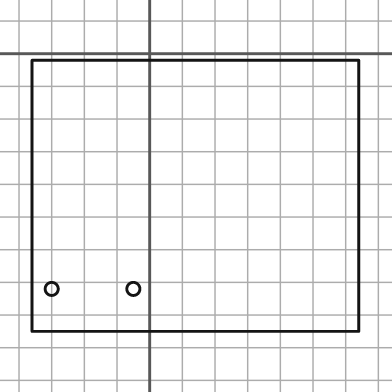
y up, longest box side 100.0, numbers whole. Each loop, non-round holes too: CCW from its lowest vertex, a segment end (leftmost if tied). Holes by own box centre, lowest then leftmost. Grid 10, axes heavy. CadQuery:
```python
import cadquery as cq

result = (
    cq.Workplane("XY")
    .moveTo(-36.0, -85.0)
    .lineTo(64.0, -85.0)
    .lineTo(64.0, -2.0)
    .lineTo(-36.0, -2.0)
    .close()
    .moveTo(-30.0, -72.0)
    .circle(2.0)
    .moveTo(-5.0, -72.0)
    .circle(2.0)
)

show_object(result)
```